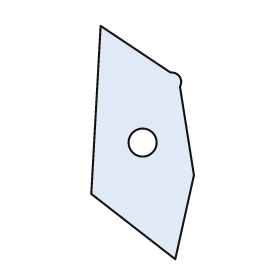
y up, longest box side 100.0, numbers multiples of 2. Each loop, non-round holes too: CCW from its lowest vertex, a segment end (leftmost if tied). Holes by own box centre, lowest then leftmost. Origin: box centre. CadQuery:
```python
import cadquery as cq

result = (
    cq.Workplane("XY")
    .moveTo(14.0, -50.0)
    .lineTo(22.0, -14.0)
    .lineTo(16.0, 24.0)
    .threePointArc((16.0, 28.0), (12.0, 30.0))
    .lineTo(-18.0, 50.0)
    .lineTo(-22.0, -22.0)
    .close()
    .moveTo(0.0, 0.0)
    .circle(6.0)
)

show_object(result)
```